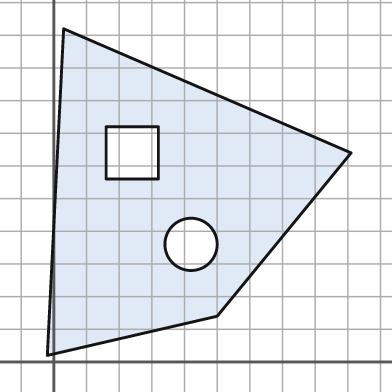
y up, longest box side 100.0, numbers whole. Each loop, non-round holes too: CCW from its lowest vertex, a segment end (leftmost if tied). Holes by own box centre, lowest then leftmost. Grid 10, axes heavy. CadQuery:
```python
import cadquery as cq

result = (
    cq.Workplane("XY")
    .moveTo(-2.0, 2.0)
    .lineTo(50.0, 14.0)
    .lineTo(91.0, 64.0)
    .lineTo(3.0, 102.0)
    .close()
    .moveTo(42.0, 36.0)
    .circle(8.0)
    .moveTo(16.0, 56.0)
    .lineTo(32.0, 56.0)
    .lineTo(32.0, 72.0)
    .lineTo(16.0, 72.0)
    .close()
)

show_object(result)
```